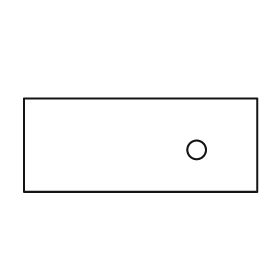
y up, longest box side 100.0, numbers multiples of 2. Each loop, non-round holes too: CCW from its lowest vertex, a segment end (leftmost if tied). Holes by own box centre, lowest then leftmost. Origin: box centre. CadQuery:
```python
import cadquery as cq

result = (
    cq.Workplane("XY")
    .moveTo(-50.0, -20.0)
    .lineTo(50.0, -20.0)
    .lineTo(50.0, 20.0)
    .lineTo(-50.0, 20.0)
    .close()
    .moveTo(24.0, -2.0)
    .circle(4.0)
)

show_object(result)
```